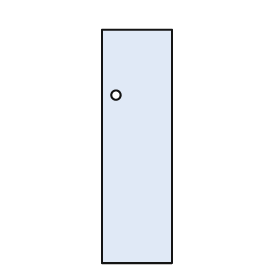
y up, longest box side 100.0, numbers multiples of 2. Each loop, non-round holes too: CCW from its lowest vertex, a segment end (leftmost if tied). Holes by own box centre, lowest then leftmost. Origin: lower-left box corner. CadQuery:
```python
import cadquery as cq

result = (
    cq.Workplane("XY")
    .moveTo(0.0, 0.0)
    .lineTo(30.0, 0.0)
    .lineTo(30.0, 100.0)
    .lineTo(0.0, 100.0)
    .close()
    .moveTo(6.0, 72.0)
    .circle(2.0)
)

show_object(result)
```